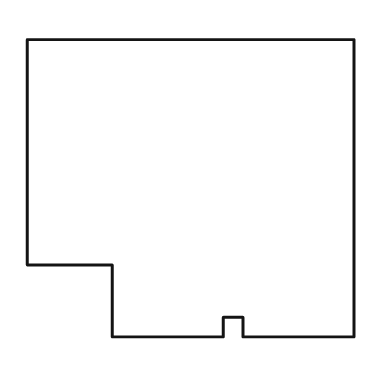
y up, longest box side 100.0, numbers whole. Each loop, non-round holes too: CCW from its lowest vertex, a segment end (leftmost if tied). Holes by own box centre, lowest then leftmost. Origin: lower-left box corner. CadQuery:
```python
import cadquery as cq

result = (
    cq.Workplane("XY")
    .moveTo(26.0, 0.0)
    .lineTo(60.0, 0.0)
    .lineTo(60.0, 6.0)
    .lineTo(66.0, 6.0)
    .lineTo(66.0, 0.0)
    .lineTo(100.0, 0.0)
    .lineTo(100.0, 91.0)
    .lineTo(0.0, 91.0)
    .lineTo(0.0, 22.0)
    .lineTo(26.0, 22.0)
    .close()
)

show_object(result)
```